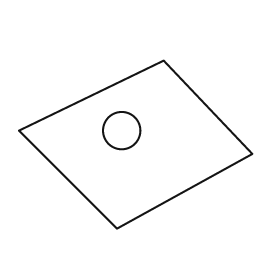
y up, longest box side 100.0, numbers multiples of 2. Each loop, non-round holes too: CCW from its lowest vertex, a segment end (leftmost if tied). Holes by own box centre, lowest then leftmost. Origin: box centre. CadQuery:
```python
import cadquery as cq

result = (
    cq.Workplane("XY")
    .moveTo(-8.0, -36.0)
    .lineTo(50.0, -4.0)
    .lineTo(12.0, 36.0)
    .lineTo(-50.0, 6.0)
    .close()
    .moveTo(-6.0, 6.0)
    .circle(8.0)
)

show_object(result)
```